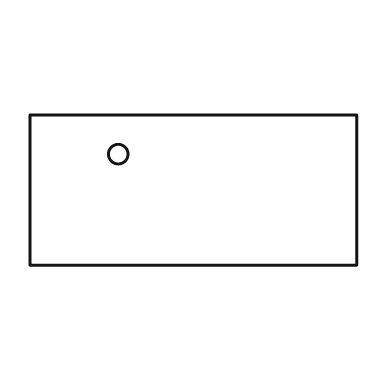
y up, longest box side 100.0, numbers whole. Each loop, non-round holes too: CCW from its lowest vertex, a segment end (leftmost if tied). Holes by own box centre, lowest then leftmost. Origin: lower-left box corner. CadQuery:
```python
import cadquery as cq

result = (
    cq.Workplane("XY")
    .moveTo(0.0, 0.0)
    .lineTo(100.0, 0.0)
    .lineTo(100.0, 46.0)
    .lineTo(0.0, 46.0)
    .close()
    .moveTo(27.0, 34.0)
    .circle(3.0)
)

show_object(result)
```